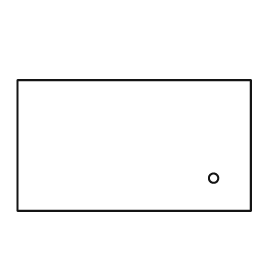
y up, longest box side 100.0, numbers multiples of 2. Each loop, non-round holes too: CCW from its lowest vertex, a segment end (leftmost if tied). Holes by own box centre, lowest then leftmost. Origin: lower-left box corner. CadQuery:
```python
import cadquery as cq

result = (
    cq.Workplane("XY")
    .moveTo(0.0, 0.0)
    .lineTo(100.0, 0.0)
    .lineTo(100.0, 56.0)
    .lineTo(0.0, 56.0)
    .close()
    .moveTo(84.0, 14.0)
    .circle(2.0)
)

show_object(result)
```